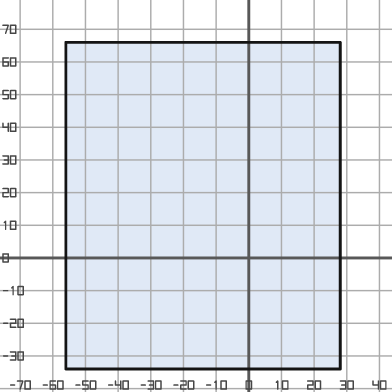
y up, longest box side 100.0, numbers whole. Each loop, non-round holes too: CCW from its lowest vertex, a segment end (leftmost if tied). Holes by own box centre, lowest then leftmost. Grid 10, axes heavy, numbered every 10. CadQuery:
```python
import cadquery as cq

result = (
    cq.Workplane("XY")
    .moveTo(-56.0, -34.0)
    .lineTo(28.0, -34.0)
    .lineTo(28.0, 66.0)
    .lineTo(-56.0, 66.0)
    .close()
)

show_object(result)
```